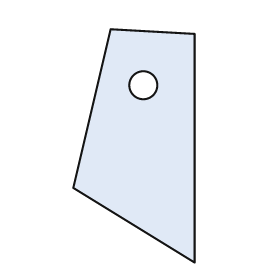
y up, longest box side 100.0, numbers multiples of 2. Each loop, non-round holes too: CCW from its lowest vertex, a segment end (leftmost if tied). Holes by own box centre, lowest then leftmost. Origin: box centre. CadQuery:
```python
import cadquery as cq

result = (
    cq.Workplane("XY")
    .moveTo(26.0, -50.0)
    .lineTo(26.0, 48.0)
    .lineTo(-10.0, 50.0)
    .lineTo(-26.0, -18.0)
    .close()
    .moveTo(4.0, 26.0)
    .circle(6.0)
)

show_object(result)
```